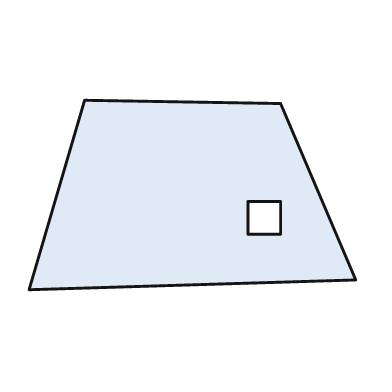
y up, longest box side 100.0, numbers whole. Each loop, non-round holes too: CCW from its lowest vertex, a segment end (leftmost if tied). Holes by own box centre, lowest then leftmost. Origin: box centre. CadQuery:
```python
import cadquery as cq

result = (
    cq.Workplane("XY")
    .moveTo(-50.0, -29.0)
    .lineTo(50.0, -26.0)
    .lineTo(27.0, 28.0)
    .lineTo(-33.0, 29.0)
    .close()
    .moveTo(17.0, -12.0)
    .lineTo(27.0, -12.0)
    .lineTo(27.0, -2.0)
    .lineTo(17.0, -2.0)
    .close()
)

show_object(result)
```